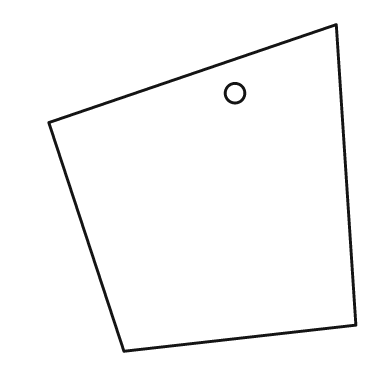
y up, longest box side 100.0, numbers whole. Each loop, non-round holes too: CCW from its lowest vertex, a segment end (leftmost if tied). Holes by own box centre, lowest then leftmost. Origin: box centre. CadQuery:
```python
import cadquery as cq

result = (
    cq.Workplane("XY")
    .moveTo(-24.0, -50.0)
    .lineTo(47.0, -42.0)
    .lineTo(41.0, 50.0)
    .lineTo(-47.0, 20.0)
    .close()
    .moveTo(10.0, 29.0)
    .circle(3.0)
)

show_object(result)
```